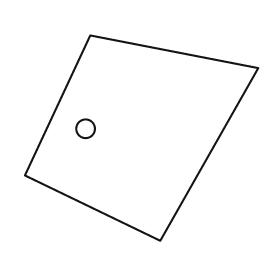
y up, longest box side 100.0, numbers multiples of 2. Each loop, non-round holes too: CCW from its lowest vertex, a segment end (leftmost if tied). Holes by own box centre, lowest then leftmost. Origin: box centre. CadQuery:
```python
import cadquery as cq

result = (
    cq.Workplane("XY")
    .moveTo(8.0, -44.0)
    .lineTo(50.0, 30.0)
    .lineTo(-22.0, 44.0)
    .lineTo(-50.0, -16.0)
    .close()
    .moveTo(-24.0, 4.0)
    .circle(4.0)
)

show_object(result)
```